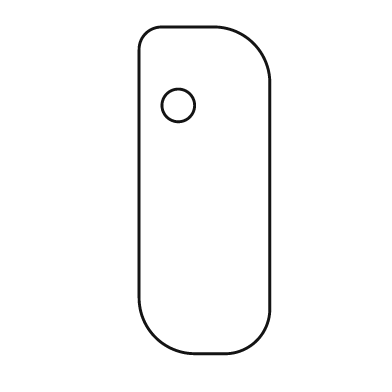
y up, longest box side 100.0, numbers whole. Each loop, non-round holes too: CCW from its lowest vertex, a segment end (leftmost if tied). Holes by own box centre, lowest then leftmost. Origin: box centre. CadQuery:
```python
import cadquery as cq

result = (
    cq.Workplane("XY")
    .moveTo(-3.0, -50.0)
    .lineTo(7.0, -50.0)
    .threePointArc((16.0, -46.0), (20.0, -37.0))
    .lineTo(20.0, 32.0)
    .threePointArc((15.0, 45.0), (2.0, 50.0))
    .lineTo(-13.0, 50.0)
    .threePointArc((-18.0, 48.0), (-20.0, 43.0))
    .lineTo(-20.0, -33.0)
    .threePointArc((-15.0, -45.0), (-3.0, -50.0))
    .close()
    .moveTo(-8.0, 26.0)
    .circle(5.0)
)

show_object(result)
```